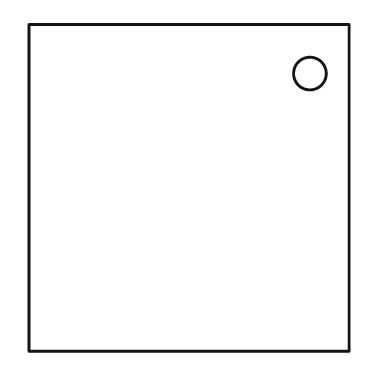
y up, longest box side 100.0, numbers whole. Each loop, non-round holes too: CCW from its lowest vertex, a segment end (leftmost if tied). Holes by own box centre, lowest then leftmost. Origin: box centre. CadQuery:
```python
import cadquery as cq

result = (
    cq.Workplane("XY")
    .moveTo(-49.0, -50.0)
    .lineTo(49.0, -50.0)
    .lineTo(49.0, 50.0)
    .lineTo(-49.0, 50.0)
    .close()
    .moveTo(37.0, 35.0)
    .circle(5.0)
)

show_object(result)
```